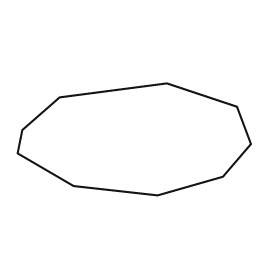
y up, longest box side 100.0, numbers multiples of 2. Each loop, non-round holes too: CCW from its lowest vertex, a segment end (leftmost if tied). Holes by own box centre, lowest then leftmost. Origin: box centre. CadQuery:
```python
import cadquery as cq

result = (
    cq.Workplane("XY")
    .moveTo(10.0, -24.0)
    .lineTo(38.0, -16.0)
    .lineTo(50.0, -2.0)
    .lineTo(44.0, 14.0)
    .lineTo(14.0, 24.0)
    .lineTo(-32.0, 18.0)
    .lineTo(-48.0, 4.0)
    .lineTo(-50.0, -6.0)
    .lineTo(-26.0, -20.0)
    .close()
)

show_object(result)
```